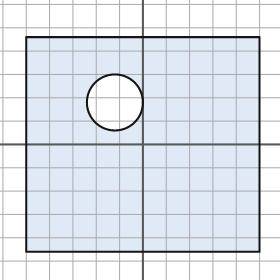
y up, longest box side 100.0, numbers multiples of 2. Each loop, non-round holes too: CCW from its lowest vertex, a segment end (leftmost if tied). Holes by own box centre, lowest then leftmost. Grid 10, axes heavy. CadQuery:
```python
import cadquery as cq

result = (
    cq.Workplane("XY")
    .moveTo(-50.0, -46.0)
    .lineTo(50.0, -46.0)
    .lineTo(50.0, 46.0)
    .lineTo(-50.0, 46.0)
    .close()
    .moveTo(-12.0, 18.0)
    .circle(12.0)
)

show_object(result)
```